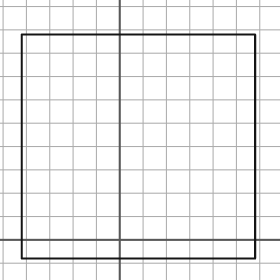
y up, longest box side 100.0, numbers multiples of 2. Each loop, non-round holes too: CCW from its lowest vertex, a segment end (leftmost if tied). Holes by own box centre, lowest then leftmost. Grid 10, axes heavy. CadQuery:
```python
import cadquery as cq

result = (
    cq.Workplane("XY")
    .moveTo(-42.0, -8.0)
    .lineTo(58.0, -8.0)
    .lineTo(58.0, 88.0)
    .lineTo(-42.0, 88.0)
    .close()
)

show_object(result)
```